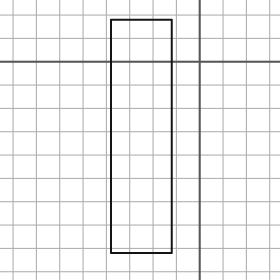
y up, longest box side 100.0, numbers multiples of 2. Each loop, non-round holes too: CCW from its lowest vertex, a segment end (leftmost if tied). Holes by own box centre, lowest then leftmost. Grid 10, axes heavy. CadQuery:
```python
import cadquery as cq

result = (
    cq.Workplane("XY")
    .moveTo(-38.0, -82.0)
    .lineTo(-12.0, -82.0)
    .lineTo(-12.0, 18.0)
    .lineTo(-38.0, 18.0)
    .close()
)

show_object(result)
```